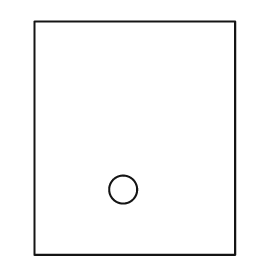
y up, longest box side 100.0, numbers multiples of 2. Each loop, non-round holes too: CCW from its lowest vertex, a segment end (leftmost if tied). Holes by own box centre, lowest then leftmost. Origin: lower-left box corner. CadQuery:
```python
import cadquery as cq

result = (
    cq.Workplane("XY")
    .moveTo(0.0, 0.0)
    .lineTo(86.0, 0.0)
    .lineTo(86.0, 100.0)
    .lineTo(0.0, 100.0)
    .close()
    .moveTo(38.0, 28.0)
    .circle(6.0)
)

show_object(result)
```